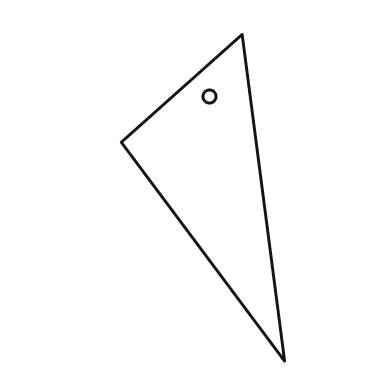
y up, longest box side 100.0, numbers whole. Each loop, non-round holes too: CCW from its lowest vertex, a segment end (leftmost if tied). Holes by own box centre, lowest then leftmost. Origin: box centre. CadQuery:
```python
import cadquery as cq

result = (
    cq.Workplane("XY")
    .moveTo(25.0, -50.0)
    .lineTo(12.0, 50.0)
    .lineTo(-25.0, 17.0)
    .close()
    .moveTo(2.0, 31.0)
    .circle(2.0)
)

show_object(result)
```